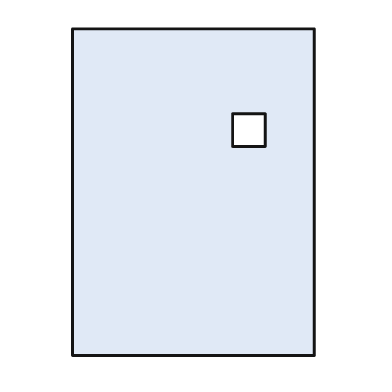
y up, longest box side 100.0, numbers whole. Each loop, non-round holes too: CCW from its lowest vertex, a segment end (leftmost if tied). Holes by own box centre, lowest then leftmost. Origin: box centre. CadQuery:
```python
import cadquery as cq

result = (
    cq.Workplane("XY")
    .moveTo(-37.0, -50.0)
    .lineTo(37.0, -50.0)
    .lineTo(37.0, 50.0)
    .lineTo(-37.0, 50.0)
    .close()
    .moveTo(12.0, 14.0)
    .lineTo(22.0, 14.0)
    .lineTo(22.0, 24.0)
    .lineTo(12.0, 24.0)
    .close()
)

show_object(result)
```